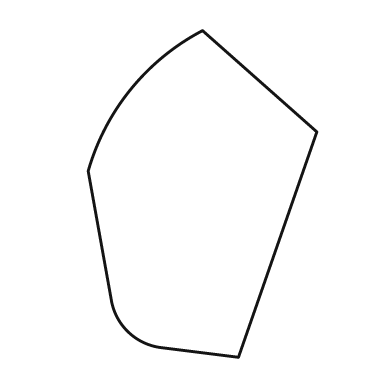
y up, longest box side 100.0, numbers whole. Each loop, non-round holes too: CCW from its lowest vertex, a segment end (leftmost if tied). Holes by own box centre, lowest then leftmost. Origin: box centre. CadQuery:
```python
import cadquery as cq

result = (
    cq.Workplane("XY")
    .moveTo(11.0, -50.0)
    .lineTo(35.0, 19.0)
    .lineTo(0.0, 50.0)
    .threePointArc((-22.0, 32.0), (-35.0, 7.0))
    .lineTo(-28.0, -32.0)
    .threePointArc((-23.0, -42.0), (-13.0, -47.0))
    .close()
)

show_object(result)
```